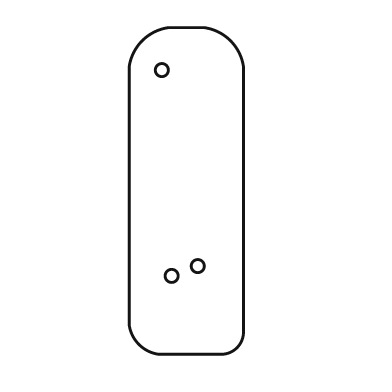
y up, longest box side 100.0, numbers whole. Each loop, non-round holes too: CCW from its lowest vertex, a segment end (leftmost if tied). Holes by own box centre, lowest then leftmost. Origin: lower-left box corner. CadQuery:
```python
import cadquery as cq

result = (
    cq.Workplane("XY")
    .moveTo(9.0, 0.0)
    .lineTo(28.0, 0.0)
    .threePointArc((33.0, 2.0), (35.0, 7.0))
    .lineTo(35.0, 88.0)
    .threePointArc((31.0, 96.0), (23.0, 100.0))
    .lineTo(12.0, 100.0)
    .threePointArc((4.0, 96.0), (0.0, 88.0))
    .lineTo(0.0, 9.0)
    .threePointArc((3.0, 3.0), (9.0, 0.0))
    .close()
    .moveTo(13.0, 24.0)
    .circle(2.0)
    .moveTo(21.0, 27.0)
    .circle(2.0)
    .moveTo(10.0, 87.0)
    .circle(2.0)
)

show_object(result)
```